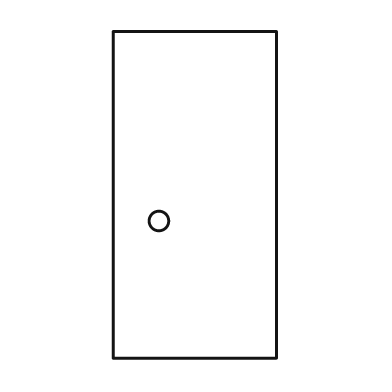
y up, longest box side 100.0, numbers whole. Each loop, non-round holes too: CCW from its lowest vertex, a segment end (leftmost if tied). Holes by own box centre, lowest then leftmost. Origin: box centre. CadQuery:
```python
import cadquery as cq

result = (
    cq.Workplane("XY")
    .moveTo(-25.0, -50.0)
    .lineTo(25.0, -50.0)
    .lineTo(25.0, 50.0)
    .lineTo(-25.0, 50.0)
    .close()
    .moveTo(-11.0, -8.0)
    .circle(3.0)
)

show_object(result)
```